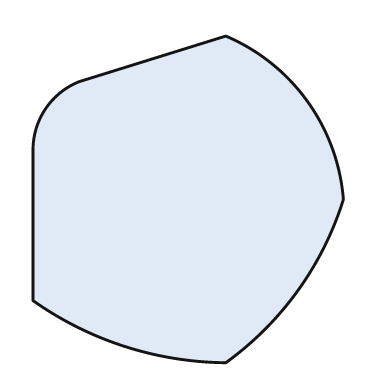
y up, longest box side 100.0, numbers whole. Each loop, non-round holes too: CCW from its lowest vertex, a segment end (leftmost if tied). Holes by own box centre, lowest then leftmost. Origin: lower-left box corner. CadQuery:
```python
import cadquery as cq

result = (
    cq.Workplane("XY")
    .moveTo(59.0, 0.0)
    .threePointArc((81.0, 22.0), (95.0, 50.0))
    .threePointArc((84.0, 80.0), (59.0, 100.0))
    .lineTo(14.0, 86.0)
    .threePointArc((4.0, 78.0), (0.0, 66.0))
    .lineTo(0.0, 19.0)
    .threePointArc((28.0, 5.0), (59.0, 0.0))
    .close()
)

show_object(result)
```